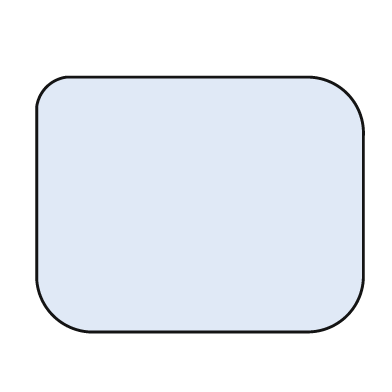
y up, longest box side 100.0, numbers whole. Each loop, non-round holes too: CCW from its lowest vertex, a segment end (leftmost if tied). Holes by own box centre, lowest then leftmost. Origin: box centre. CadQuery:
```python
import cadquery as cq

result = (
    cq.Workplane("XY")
    .moveTo(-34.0, -39.0)
    .lineTo(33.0, -39.0)
    .threePointArc((45.0, -34.0), (50.0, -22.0))
    .lineTo(50.0, 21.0)
    .threePointArc((45.0, 34.0), (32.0, 39.0))
    .lineTo(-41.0, 39.0)
    .threePointArc((-47.0, 36.0), (-50.0, 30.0))
    .lineTo(-50.0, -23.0)
    .threePointArc((-45.0, -34.0), (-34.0, -39.0))
    .close()
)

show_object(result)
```